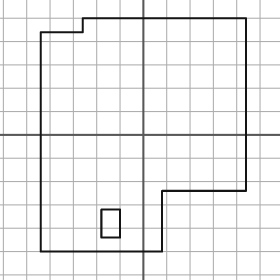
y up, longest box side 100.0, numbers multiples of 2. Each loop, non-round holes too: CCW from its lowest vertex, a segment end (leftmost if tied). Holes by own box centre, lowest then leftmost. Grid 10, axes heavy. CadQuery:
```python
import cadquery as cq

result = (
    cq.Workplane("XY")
    .moveTo(-44.0, -50.0)
    .lineTo(8.0, -50.0)
    .lineTo(8.0, -24.0)
    .lineTo(44.0, -24.0)
    .lineTo(44.0, 50.0)
    .lineTo(-26.0, 50.0)
    .lineTo(-26.0, 44.0)
    .lineTo(-44.0, 44.0)
    .close()
    .moveTo(-18.0, -44.0)
    .lineTo(-10.0, -44.0)
    .lineTo(-10.0, -32.0)
    .lineTo(-18.0, -32.0)
    .close()
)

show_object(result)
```